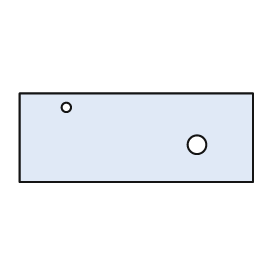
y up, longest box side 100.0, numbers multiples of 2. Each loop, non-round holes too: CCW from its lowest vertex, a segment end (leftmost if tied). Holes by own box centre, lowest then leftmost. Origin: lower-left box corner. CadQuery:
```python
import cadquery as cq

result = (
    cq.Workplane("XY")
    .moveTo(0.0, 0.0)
    .lineTo(100.0, 0.0)
    .lineTo(100.0, 38.0)
    .lineTo(0.0, 38.0)
    .close()
    .moveTo(76.0, 16.0)
    .circle(4.0)
    .moveTo(20.0, 32.0)
    .circle(2.0)
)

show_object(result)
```